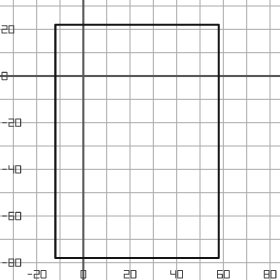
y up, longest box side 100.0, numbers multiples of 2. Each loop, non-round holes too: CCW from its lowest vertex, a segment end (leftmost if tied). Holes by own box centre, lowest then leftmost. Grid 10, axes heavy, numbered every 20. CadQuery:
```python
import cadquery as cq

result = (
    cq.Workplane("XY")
    .moveTo(-12.0, -78.0)
    .lineTo(58.0, -78.0)
    .lineTo(58.0, 22.0)
    .lineTo(-12.0, 22.0)
    .close()
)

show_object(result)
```